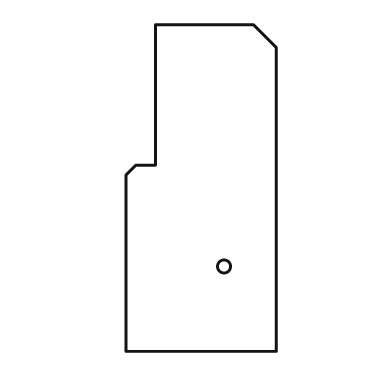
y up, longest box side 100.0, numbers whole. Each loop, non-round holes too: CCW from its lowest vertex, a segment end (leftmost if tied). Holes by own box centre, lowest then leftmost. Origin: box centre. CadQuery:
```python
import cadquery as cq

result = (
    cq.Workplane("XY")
    .moveTo(-23.0, -50.0)
    .lineTo(23.0, -50.0)
    .lineTo(23.0, 43.0)
    .lineTo(16.0, 50.0)
    .lineTo(-14.0, 50.0)
    .lineTo(-14.0, 7.0)
    .lineTo(-20.0, 7.0)
    .lineTo(-23.0, 4.0)
    .close()
    .moveTo(7.0, -24.0)
    .circle(2.0)
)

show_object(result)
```